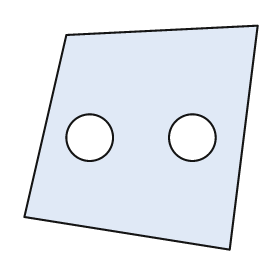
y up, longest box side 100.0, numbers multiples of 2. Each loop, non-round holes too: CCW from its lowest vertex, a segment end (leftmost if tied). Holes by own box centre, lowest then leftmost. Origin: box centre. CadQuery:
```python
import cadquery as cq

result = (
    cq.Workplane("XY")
    .moveTo(38.0, -48.0)
    .lineTo(50.0, 48.0)
    .lineTo(-32.0, 44.0)
    .lineTo(-50.0, -34.0)
    .close()
    .moveTo(-22.0, 0.0)
    .circle(10.0)
    .moveTo(22.0, 0.0)
    .circle(10.0)
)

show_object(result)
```